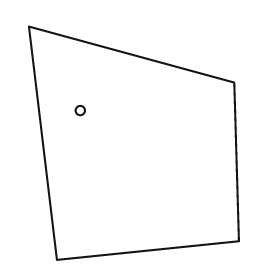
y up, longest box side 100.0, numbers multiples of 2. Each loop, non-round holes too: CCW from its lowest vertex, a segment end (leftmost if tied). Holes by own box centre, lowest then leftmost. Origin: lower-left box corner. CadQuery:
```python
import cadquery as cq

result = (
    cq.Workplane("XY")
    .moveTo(12.0, 0.0)
    .lineTo(90.0, 8.0)
    .lineTo(88.0, 76.0)
    .lineTo(0.0, 100.0)
    .close()
    .moveTo(22.0, 64.0)
    .circle(2.0)
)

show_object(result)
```